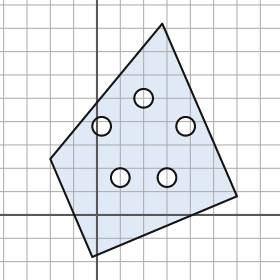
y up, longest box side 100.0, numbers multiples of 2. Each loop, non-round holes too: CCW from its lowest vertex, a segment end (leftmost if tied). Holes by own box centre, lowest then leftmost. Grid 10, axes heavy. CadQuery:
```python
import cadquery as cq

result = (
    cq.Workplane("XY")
    .moveTo(-2.0, -18.0)
    .lineTo(60.0, 8.0)
    .lineTo(28.0, 82.0)
    .lineTo(-20.0, 24.0)
    .close()
    .moveTo(10.0, 16.0)
    .circle(4.0)
    .moveTo(30.0, 16.0)
    .circle(4.0)
    .moveTo(2.0, 38.0)
    .circle(4.0)
    .moveTo(38.0, 38.0)
    .circle(4.0)
    .moveTo(20.0, 50.0)
    .circle(4.0)
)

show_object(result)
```